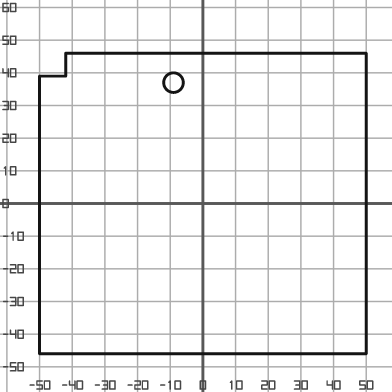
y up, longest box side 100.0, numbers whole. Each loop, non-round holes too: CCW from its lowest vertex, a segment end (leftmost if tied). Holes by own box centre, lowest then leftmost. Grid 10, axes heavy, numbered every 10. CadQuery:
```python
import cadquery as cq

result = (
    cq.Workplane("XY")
    .moveTo(-50.0, -46.0)
    .lineTo(50.0, -46.0)
    .lineTo(50.0, 46.0)
    .lineTo(-42.0, 46.0)
    .lineTo(-42.0, 39.0)
    .lineTo(-50.0, 39.0)
    .close()
    .moveTo(-9.0, 37.0)
    .circle(3.0)
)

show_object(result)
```